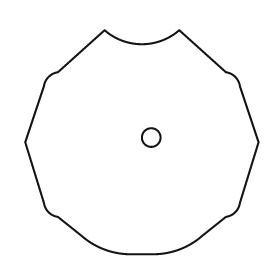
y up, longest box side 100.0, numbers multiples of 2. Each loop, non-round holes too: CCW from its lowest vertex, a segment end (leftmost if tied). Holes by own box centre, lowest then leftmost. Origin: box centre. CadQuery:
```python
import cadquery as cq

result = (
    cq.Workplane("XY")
    .moveTo(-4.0, -48.0)
    .lineTo(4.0, -48.0)
    .threePointArc((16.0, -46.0), (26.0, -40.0))
    .lineTo(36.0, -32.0)
    .threePointArc((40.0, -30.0), (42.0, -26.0))
    .lineTo(50.0, 0.0)
    .lineTo(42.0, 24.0)
    .threePointArc((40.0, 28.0), (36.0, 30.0))
    .lineTo(16.0, 48.0)
    .threePointArc((0.0, 42.0), (-16.0, 48.0))
    .lineTo(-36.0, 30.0)
    .threePointArc((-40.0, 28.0), (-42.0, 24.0))
    .lineTo(-50.0, 0.0)
    .lineTo(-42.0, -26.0)
    .threePointArc((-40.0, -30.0), (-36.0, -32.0))
    .lineTo(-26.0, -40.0)
    .threePointArc((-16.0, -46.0), (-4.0, -48.0))
    .close()
    .moveTo(4.0, 2.0)
    .circle(4.0)
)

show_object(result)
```